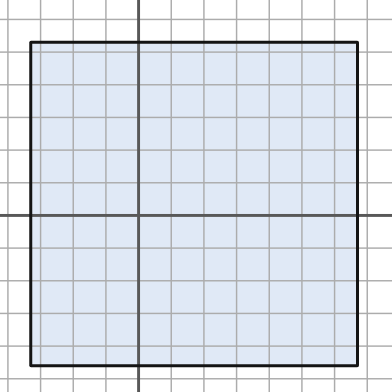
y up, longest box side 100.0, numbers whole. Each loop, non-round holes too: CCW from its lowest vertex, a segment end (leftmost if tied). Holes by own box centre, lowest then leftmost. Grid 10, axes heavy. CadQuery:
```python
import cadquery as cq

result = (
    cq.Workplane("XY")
    .moveTo(-33.0, -46.0)
    .lineTo(67.0, -46.0)
    .lineTo(67.0, 53.0)
    .lineTo(-33.0, 53.0)
    .close()
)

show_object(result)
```